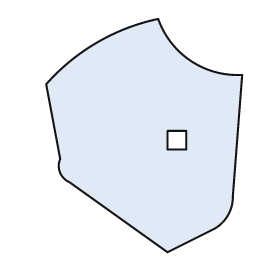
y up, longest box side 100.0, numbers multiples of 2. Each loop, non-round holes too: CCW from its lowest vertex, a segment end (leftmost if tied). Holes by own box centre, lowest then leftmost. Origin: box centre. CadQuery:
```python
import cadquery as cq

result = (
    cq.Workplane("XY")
    .moveTo(10.0, -50.0)
    .lineTo(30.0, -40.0)
    .threePointArc((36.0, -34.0), (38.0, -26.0))
    .lineTo(42.0, 26.0)
    .threePointArc((20.0, 32.0), (6.0, 50.0))
    .threePointArc((-20.0, 40.0), (-42.0, 22.0))
    .lineTo(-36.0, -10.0)
    .threePointArc((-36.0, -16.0), (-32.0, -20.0))
    .close()
    .moveTo(10.0, -6.0)
    .lineTo(18.0, -6.0)
    .lineTo(18.0, 2.0)
    .lineTo(10.0, 2.0)
    .close()
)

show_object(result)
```